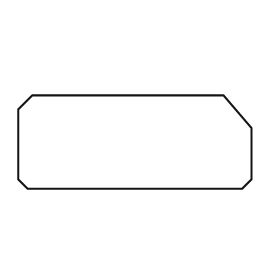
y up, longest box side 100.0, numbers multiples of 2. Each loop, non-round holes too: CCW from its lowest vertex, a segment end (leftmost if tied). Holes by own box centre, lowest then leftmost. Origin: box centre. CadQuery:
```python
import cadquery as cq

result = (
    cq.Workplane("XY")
    .moveTo(-46.0, -20.0)
    .lineTo(46.0, -20.0)
    .lineTo(50.0, -16.0)
    .lineTo(50.0, 6.0)
    .lineTo(38.0, 20.0)
    .lineTo(-44.0, 20.0)
    .lineTo(-50.0, 14.0)
    .lineTo(-50.0, -16.0)
    .close()
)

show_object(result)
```